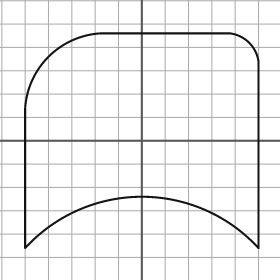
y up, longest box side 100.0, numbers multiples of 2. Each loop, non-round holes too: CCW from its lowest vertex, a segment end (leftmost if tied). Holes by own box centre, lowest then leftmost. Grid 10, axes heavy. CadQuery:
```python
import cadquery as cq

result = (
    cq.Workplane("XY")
    .moveTo(-50.0, -46.0)
    .threePointArc((0.0, -24.0), (50.0, -46.0))
    .lineTo(50.0, 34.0)
    .threePointArc((46.0, 42.0), (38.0, 46.0))
    .lineTo(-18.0, 46.0)
    .threePointArc((-40.0, 36.0), (-50.0, 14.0))
    .close()
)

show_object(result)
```